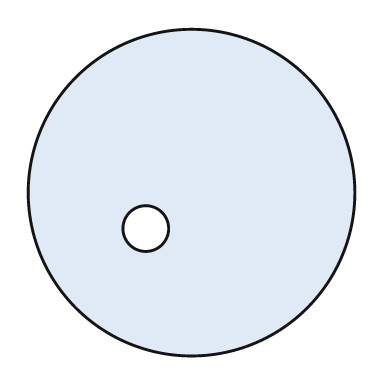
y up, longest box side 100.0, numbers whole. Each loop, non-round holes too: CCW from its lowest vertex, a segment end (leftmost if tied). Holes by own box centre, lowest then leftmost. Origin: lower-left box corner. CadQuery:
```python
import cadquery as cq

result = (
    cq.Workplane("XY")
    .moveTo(50.0, 50.0)
    .circle(50.0)
    .moveTo(36.0, 39.0)
    .circle(7.0)
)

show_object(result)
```